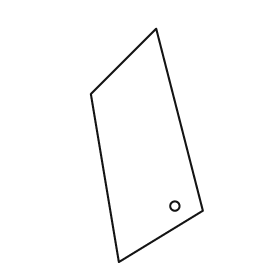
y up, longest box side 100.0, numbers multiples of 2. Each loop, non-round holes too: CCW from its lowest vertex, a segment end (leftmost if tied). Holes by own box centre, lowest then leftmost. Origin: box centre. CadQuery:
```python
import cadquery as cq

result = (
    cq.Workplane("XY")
    .moveTo(-12.0, -50.0)
    .lineTo(24.0, -28.0)
    .lineTo(4.0, 50.0)
    .lineTo(-24.0, 22.0)
    .close()
    .moveTo(12.0, -26.0)
    .circle(2.0)
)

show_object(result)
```